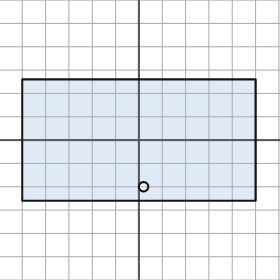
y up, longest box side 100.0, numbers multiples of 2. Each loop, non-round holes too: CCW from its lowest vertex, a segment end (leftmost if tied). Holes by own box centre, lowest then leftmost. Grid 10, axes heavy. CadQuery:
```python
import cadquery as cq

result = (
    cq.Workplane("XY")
    .moveTo(-50.0, -26.0)
    .lineTo(50.0, -26.0)
    .lineTo(50.0, 26.0)
    .lineTo(-50.0, 26.0)
    .close()
    .moveTo(2.0, -20.0)
    .circle(2.0)
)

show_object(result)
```